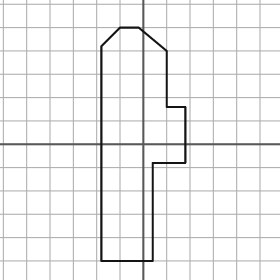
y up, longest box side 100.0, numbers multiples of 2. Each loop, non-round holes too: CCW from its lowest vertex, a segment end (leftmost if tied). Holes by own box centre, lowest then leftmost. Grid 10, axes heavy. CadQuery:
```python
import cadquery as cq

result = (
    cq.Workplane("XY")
    .moveTo(-18.0, -50.0)
    .lineTo(4.0, -50.0)
    .lineTo(4.0, -8.0)
    .lineTo(18.0, -8.0)
    .lineTo(18.0, 16.0)
    .lineTo(10.0, 16.0)
    .lineTo(10.0, 40.0)
    .lineTo(-2.0, 50.0)
    .lineTo(-10.0, 50.0)
    .lineTo(-18.0, 42.0)
    .close()
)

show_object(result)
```